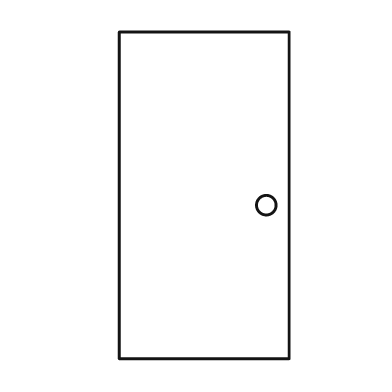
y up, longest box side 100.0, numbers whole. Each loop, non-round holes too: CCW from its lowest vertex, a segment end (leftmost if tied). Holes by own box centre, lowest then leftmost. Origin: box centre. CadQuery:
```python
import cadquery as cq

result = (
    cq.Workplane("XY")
    .moveTo(-26.0, -50.0)
    .lineTo(26.0, -50.0)
    .lineTo(26.0, 50.0)
    .lineTo(-26.0, 50.0)
    .close()
    .moveTo(19.0, -3.0)
    .circle(3.0)
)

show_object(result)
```